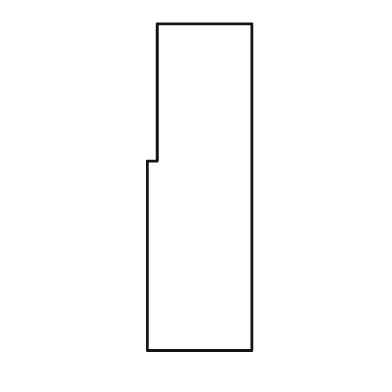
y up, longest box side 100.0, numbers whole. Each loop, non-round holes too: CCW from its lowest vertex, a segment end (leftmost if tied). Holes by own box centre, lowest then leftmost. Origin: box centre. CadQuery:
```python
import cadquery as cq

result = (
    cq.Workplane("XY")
    .moveTo(-16.0, -50.0)
    .lineTo(16.0, -50.0)
    .lineTo(16.0, 50.0)
    .lineTo(-13.0, 50.0)
    .lineTo(-13.0, 8.0)
    .lineTo(-16.0, 8.0)
    .close()
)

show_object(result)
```